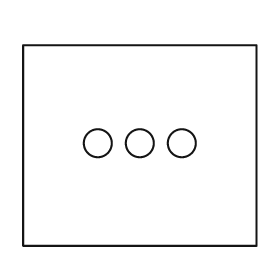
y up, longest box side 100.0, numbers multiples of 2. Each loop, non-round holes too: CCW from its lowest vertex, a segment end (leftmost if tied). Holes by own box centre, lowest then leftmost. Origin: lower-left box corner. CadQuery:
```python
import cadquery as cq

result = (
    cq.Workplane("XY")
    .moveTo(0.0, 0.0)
    .lineTo(100.0, 0.0)
    .lineTo(100.0, 86.0)
    .lineTo(0.0, 86.0)
    .close()
    .moveTo(32.0, 44.0)
    .circle(6.0)
    .moveTo(50.0, 44.0)
    .circle(6.0)
    .moveTo(68.0, 44.0)
    .circle(6.0)
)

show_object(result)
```